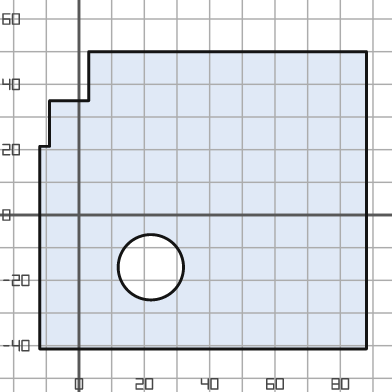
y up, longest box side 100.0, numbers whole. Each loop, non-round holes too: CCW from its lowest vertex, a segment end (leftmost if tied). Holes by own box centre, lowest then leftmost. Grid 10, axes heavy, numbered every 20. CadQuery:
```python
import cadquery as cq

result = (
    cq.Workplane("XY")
    .moveTo(-12.0, -41.0)
    .lineTo(88.0, -41.0)
    .lineTo(88.0, 50.0)
    .lineTo(3.0, 50.0)
    .lineTo(3.0, 35.0)
    .lineTo(-9.0, 35.0)
    .lineTo(-9.0, 21.0)
    .lineTo(-12.0, 21.0)
    .close()
    .moveTo(22.0, -16.0)
    .circle(10.0)
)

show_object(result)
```